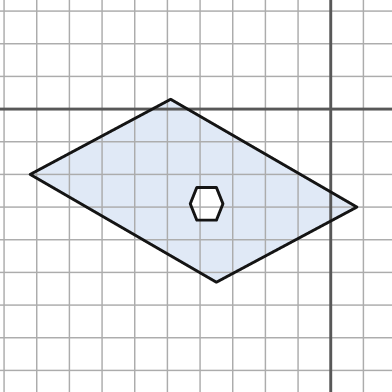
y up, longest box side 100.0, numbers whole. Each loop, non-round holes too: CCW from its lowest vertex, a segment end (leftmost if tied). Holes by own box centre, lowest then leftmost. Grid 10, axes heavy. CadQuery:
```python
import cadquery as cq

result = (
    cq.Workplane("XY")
    .moveTo(-35.0, -53.0)
    .lineTo(8.0, -30.0)
    .lineTo(-49.0, 3.0)
    .lineTo(-92.0, -20.0)
    .close()
    .moveTo(-41.0, -34.0)
    .lineTo(-35.0, -34.0)
    .lineTo(-33.0, -29.0)
    .lineTo(-35.0, -24.0)
    .lineTo(-41.0, -24.0)
    .lineTo(-43.0, -29.0)
    .close()
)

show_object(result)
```